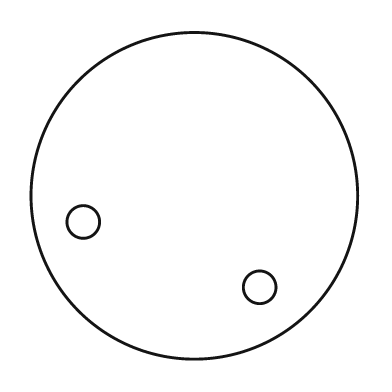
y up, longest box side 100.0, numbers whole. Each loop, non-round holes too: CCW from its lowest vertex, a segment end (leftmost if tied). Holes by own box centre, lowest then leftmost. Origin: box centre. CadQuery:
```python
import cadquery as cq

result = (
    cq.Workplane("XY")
    .moveTo(0.0, 0.0)
    .circle(50.0)
    .moveTo(20.0, -28.0)
    .circle(5.0)
    .moveTo(-34.0, -8.0)
    .circle(5.0)
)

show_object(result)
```